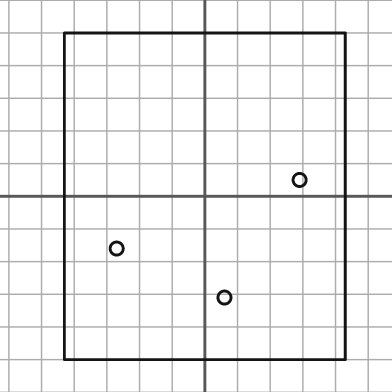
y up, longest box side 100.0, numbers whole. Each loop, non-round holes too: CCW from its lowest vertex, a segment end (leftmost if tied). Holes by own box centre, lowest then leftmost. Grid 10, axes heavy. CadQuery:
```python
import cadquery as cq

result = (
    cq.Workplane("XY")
    .moveTo(-43.0, -50.0)
    .lineTo(43.0, -50.0)
    .lineTo(43.0, 50.0)
    .lineTo(-43.0, 50.0)
    .close()
    .moveTo(6.0, -31.0)
    .circle(2.0)
    .moveTo(-27.0, -16.0)
    .circle(2.0)
    .moveTo(29.0, 5.0)
    .circle(2.0)
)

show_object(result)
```